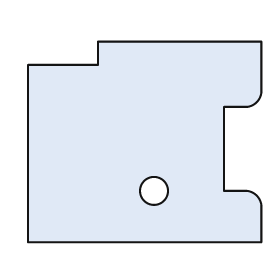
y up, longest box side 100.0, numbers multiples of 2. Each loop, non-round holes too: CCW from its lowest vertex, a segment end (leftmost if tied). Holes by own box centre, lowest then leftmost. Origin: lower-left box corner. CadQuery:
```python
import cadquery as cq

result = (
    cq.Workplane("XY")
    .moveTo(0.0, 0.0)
    .lineTo(100.0, 0.0)
    .lineTo(100.0, 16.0)
    .threePointArc((98.0, 20.0), (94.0, 22.0))
    .lineTo(84.0, 22.0)
    .lineTo(84.0, 58.0)
    .lineTo(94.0, 58.0)
    .threePointArc((98.0, 60.0), (100.0, 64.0))
    .lineTo(100.0, 86.0)
    .lineTo(30.0, 86.0)
    .lineTo(30.0, 76.0)
    .lineTo(0.0, 76.0)
    .close()
    .moveTo(54.0, 22.0)
    .circle(6.0)
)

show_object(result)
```